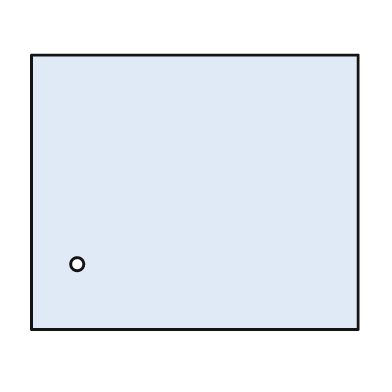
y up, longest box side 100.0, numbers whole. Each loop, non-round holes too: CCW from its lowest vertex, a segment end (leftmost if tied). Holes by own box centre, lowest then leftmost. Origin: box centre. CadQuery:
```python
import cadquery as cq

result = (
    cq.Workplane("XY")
    .moveTo(-50.0, -42.0)
    .lineTo(50.0, -42.0)
    .lineTo(50.0, 42.0)
    .lineTo(-50.0, 42.0)
    .close()
    .moveTo(-36.0, -22.0)
    .circle(2.0)
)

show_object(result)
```